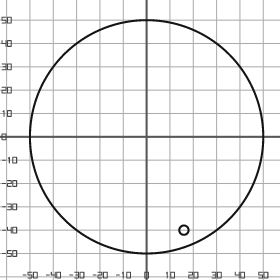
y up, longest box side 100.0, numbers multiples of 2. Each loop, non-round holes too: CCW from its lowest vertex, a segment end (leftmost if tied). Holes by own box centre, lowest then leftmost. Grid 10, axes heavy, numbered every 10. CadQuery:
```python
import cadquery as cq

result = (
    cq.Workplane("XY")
    .moveTo(0.0, 0.0)
    .circle(50.0)
    .moveTo(16.0, -40.0)
    .circle(2.0)
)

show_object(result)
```